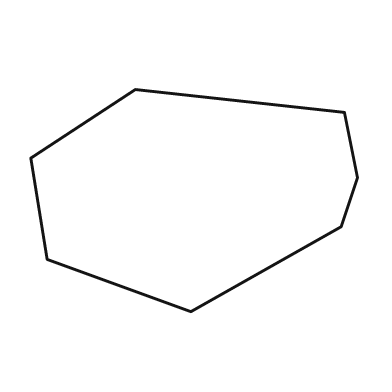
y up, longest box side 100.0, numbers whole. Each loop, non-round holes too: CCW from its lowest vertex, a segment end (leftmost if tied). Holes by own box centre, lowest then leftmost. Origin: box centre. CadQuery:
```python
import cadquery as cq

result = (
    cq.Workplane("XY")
    .moveTo(-1.0, -34.0)
    .lineTo(45.0, -8.0)
    .lineTo(50.0, 7.0)
    .lineTo(46.0, 27.0)
    .lineTo(-18.0, 34.0)
    .lineTo(-50.0, 13.0)
    .lineTo(-45.0, -18.0)
    .close()
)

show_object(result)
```